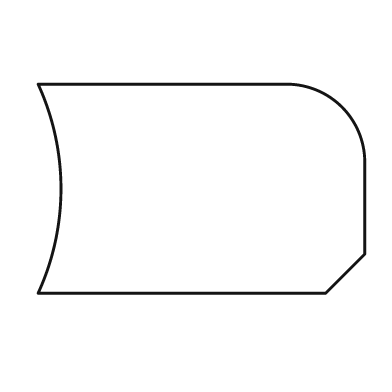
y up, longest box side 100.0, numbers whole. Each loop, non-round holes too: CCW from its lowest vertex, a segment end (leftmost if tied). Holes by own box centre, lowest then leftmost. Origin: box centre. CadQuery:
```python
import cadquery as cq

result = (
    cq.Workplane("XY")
    .moveTo(-50.0, -32.0)
    .lineTo(38.0, -32.0)
    .lineTo(50.0, -20.0)
    .lineTo(50.0, 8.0)
    .threePointArc((43.0, 25.0), (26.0, 32.0))
    .lineTo(-50.0, 32.0)
    .threePointArc((-43.0, 0.0), (-50.0, -32.0))
    .close()
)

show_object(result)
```